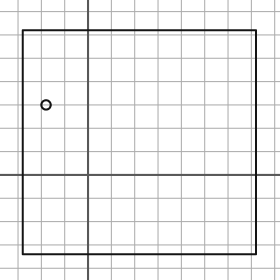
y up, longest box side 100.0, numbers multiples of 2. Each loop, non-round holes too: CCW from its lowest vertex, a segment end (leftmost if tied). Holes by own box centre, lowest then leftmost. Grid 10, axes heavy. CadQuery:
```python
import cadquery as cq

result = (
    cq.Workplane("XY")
    .moveTo(-28.0, -34.0)
    .lineTo(72.0, -34.0)
    .lineTo(72.0, 62.0)
    .lineTo(-28.0, 62.0)
    .close()
    .moveTo(-18.0, 30.0)
    .circle(2.0)
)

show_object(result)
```